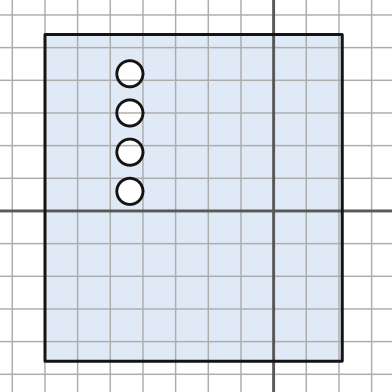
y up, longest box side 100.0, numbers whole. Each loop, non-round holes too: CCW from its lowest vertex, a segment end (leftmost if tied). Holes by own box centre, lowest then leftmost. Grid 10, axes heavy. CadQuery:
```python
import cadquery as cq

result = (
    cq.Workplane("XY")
    .moveTo(-70.0, -46.0)
    .lineTo(21.0, -46.0)
    .lineTo(21.0, 54.0)
    .lineTo(-70.0, 54.0)
    .close()
    .moveTo(-44.0, 6.0)
    .circle(4.0)
    .moveTo(-44.0, 18.0)
    .circle(4.0)
    .moveTo(-44.0, 30.0)
    .circle(4.0)
    .moveTo(-44.0, 42.0)
    .circle(4.0)
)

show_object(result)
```